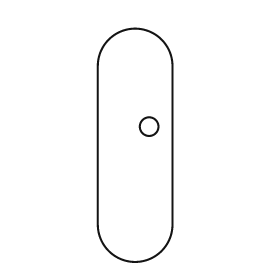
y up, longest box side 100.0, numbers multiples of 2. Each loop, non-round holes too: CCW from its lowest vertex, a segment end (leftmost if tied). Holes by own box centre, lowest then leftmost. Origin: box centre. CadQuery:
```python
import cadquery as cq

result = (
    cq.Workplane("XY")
    .moveTo(-16.0, -34.0)
    .threePointArc((0.0, -50.0), (16.0, -34.0))
    .lineTo(16.0, 34.0)
    .threePointArc((0.0, 50.0), (-16.0, 34.0))
    .close()
    .moveTo(6.0, 8.0)
    .circle(4.0)
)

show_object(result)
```